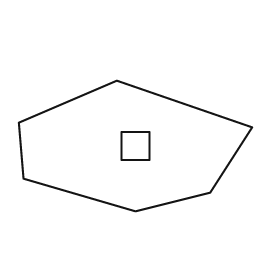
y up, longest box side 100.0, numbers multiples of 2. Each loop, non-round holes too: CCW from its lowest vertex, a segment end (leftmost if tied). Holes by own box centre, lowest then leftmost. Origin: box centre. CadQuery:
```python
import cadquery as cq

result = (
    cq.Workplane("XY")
    .moveTo(0.0, -28.0)
    .lineTo(32.0, -20.0)
    .lineTo(50.0, 8.0)
    .lineTo(-8.0, 28.0)
    .lineTo(-50.0, 10.0)
    .lineTo(-48.0, -14.0)
    .close()
    .moveTo(-6.0, -6.0)
    .lineTo(6.0, -6.0)
    .lineTo(6.0, 6.0)
    .lineTo(-6.0, 6.0)
    .close()
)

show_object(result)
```